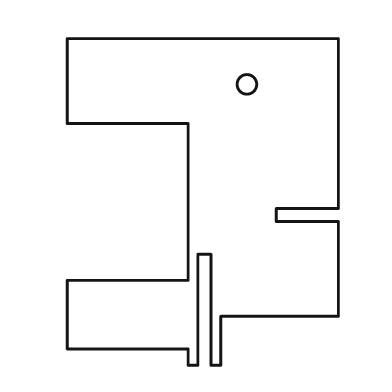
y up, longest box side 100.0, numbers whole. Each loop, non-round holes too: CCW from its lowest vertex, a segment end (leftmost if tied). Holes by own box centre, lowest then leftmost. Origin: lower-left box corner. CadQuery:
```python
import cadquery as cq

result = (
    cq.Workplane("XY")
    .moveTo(37.0, 0.0)
    .lineTo(40.0, 0.0)
    .lineTo(40.0, 34.0)
    .lineTo(44.0, 34.0)
    .lineTo(44.0, 0.0)
    .lineTo(47.0, 0.0)
    .lineTo(47.0, 15.0)
    .lineTo(83.0, 15.0)
    .lineTo(83.0, 44.0)
    .lineTo(64.0, 44.0)
    .lineTo(64.0, 48.0)
    .lineTo(83.0, 48.0)
    .lineTo(83.0, 100.0)
    .lineTo(0.0, 100.0)
    .lineTo(0.0, 74.0)
    .lineTo(37.0, 74.0)
    .lineTo(37.0, 26.0)
    .lineTo(0.0, 26.0)
    .lineTo(0.0, 5.0)
    .lineTo(37.0, 5.0)
    .close()
    .moveTo(55.0, 86.0)
    .circle(3.0)
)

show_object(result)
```